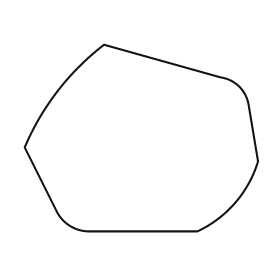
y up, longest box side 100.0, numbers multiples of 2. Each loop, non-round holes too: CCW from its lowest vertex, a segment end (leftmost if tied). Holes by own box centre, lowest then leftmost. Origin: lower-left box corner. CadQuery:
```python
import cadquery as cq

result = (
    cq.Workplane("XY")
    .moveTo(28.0, 0.0)
    .lineTo(74.0, 0.0)
    .threePointArc((90.0, 12.0), (100.0, 30.0))
    .lineTo(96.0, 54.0)
    .threePointArc((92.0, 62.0), (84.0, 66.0))
    .lineTo(34.0, 80.0)
    .threePointArc((14.0, 60.0), (0.0, 36.0))
    .lineTo(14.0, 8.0)
    .threePointArc((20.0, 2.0), (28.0, 0.0))
    .close()
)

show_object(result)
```